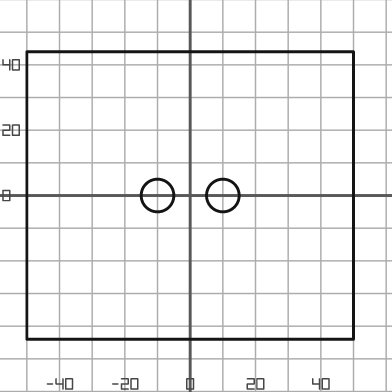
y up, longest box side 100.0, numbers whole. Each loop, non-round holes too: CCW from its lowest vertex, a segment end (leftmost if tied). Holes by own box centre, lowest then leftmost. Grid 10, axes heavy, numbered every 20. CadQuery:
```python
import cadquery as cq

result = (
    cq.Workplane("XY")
    .moveTo(-50.0, -44.0)
    .lineTo(50.0, -44.0)
    .lineTo(50.0, 44.0)
    .lineTo(-50.0, 44.0)
    .close()
    .moveTo(-10.0, 0.0)
    .circle(5.0)
    .moveTo(10.0, 0.0)
    .circle(5.0)
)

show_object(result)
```